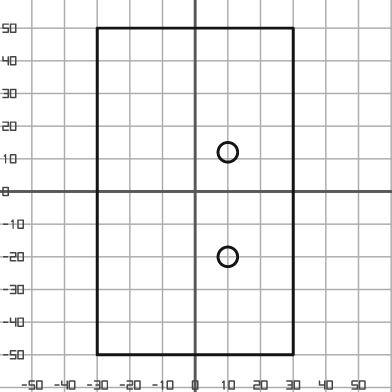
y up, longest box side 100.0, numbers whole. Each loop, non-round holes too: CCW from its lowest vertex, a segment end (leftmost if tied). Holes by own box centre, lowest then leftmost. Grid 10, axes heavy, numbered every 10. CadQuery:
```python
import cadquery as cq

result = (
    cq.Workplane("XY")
    .moveTo(-30.0, -50.0)
    .lineTo(30.0, -50.0)
    .lineTo(30.0, 50.0)
    .lineTo(-30.0, 50.0)
    .close()
    .moveTo(10.0, -20.0)
    .circle(3.0)
    .moveTo(10.0, 12.0)
    .circle(3.0)
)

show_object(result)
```